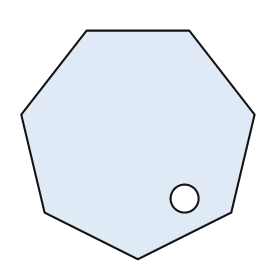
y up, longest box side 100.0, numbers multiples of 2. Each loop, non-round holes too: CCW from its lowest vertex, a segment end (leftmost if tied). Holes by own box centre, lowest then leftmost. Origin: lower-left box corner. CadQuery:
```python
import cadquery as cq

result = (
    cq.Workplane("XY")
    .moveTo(50.0, 0.0)
    .lineTo(90.0, 20.0)
    .lineTo(100.0, 62.0)
    .lineTo(72.0, 98.0)
    .lineTo(28.0, 98.0)
    .lineTo(0.0, 62.0)
    .lineTo(10.0, 20.0)
    .close()
    .moveTo(70.0, 26.0)
    .circle(6.0)
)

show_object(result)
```